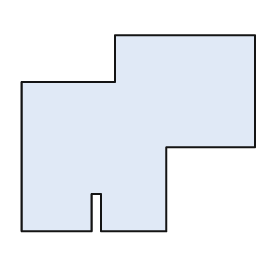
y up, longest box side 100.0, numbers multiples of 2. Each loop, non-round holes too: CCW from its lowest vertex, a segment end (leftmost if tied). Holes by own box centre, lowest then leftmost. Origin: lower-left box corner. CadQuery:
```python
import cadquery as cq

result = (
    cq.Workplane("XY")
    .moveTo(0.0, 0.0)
    .lineTo(30.0, 0.0)
    .lineTo(30.0, 16.0)
    .lineTo(34.0, 16.0)
    .lineTo(34.0, 0.0)
    .lineTo(62.0, 0.0)
    .lineTo(62.0, 36.0)
    .lineTo(100.0, 36.0)
    .lineTo(100.0, 84.0)
    .lineTo(40.0, 84.0)
    .lineTo(40.0, 64.0)
    .lineTo(0.0, 64.0)
    .close()
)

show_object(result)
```